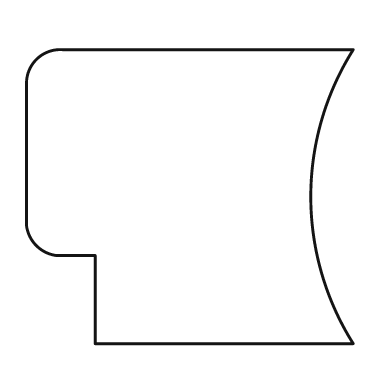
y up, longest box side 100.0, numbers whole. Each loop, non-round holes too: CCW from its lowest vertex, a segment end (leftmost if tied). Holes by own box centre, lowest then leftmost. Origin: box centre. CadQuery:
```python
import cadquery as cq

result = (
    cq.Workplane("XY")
    .moveTo(-29.0, -45.0)
    .lineTo(50.0, -45.0)
    .threePointArc((37.0, 0.0), (50.0, 45.0))
    .lineTo(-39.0, 45.0)
    .threePointArc((-47.0, 42.0), (-50.0, 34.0))
    .lineTo(-50.0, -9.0)
    .threePointArc((-47.0, -15.0), (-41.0, -18.0))
    .lineTo(-29.0, -18.0)
    .close()
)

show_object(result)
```